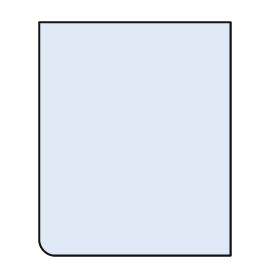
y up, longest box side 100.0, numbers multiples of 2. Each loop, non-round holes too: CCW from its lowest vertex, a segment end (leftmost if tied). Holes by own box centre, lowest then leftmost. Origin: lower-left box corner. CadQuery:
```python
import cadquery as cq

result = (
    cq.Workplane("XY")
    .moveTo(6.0, 0.0)
    .lineTo(82.0, 0.0)
    .lineTo(82.0, 100.0)
    .lineTo(0.0, 100.0)
    .lineTo(0.0, 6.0)
    .threePointArc((2.0, 2.0), (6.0, 0.0))
    .close()
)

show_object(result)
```